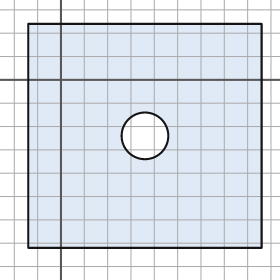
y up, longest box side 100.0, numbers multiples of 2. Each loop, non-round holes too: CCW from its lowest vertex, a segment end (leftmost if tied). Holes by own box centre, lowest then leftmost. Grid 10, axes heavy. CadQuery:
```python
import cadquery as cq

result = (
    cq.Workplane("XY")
    .moveTo(-14.0, -72.0)
    .lineTo(86.0, -72.0)
    .lineTo(86.0, 24.0)
    .lineTo(-14.0, 24.0)
    .close()
    .moveTo(36.0, -24.0)
    .circle(10.0)
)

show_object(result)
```